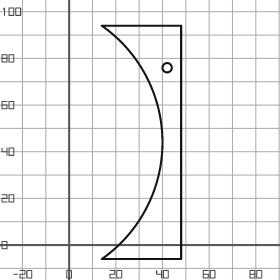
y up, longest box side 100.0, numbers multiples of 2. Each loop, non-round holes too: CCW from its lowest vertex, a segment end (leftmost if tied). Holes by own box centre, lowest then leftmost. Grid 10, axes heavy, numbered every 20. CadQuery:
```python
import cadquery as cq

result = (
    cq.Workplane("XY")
    .moveTo(14.0, -6.0)
    .lineTo(48.0, -6.0)
    .lineTo(48.0, 94.0)
    .lineTo(14.0, 94.0)
    .threePointArc((40.0, 44.0), (14.0, -6.0))
    .close()
    .moveTo(42.0, 76.0)
    .circle(2.0)
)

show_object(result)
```